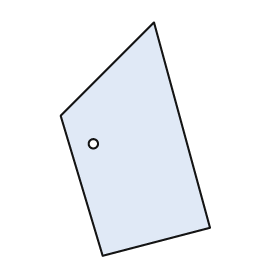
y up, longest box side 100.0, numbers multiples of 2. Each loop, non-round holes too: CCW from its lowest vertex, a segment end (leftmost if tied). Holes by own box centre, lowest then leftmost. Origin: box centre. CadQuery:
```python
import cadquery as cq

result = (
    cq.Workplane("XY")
    .moveTo(-14.0, -50.0)
    .lineTo(32.0, -38.0)
    .lineTo(8.0, 50.0)
    .lineTo(-32.0, 10.0)
    .close()
    .moveTo(-18.0, -2.0)
    .circle(2.0)
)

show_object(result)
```